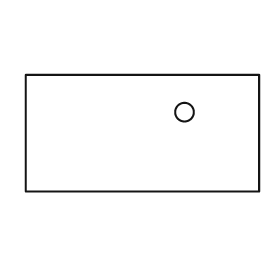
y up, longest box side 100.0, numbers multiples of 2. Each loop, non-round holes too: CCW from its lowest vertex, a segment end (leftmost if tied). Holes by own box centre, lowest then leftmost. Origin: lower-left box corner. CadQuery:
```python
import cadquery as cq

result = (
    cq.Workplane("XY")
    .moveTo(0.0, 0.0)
    .lineTo(100.0, 0.0)
    .lineTo(100.0, 50.0)
    .lineTo(0.0, 50.0)
    .close()
    .moveTo(68.0, 34.0)
    .circle(4.0)
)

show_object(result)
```